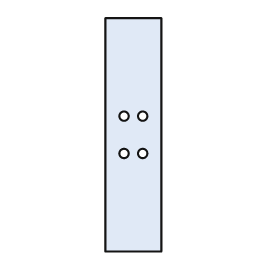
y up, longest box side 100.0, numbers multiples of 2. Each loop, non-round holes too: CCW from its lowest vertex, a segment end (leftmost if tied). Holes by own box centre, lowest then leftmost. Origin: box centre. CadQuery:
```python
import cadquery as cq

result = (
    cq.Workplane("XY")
    .moveTo(-12.0, -50.0)
    .lineTo(12.0, -50.0)
    .lineTo(12.0, 50.0)
    .lineTo(-12.0, 50.0)
    .close()
    .moveTo(-4.0, -8.0)
    .circle(2.0)
    .moveTo(4.0, -8.0)
    .circle(2.0)
    .moveTo(-4.0, 8.0)
    .circle(2.0)
    .moveTo(4.0, 8.0)
    .circle(2.0)
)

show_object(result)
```